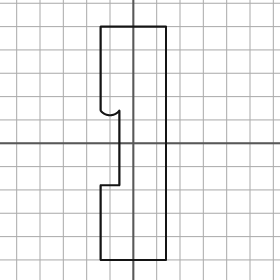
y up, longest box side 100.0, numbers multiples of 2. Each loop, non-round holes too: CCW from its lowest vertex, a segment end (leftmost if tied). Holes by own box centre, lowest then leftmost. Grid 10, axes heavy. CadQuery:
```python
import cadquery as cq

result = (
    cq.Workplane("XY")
    .moveTo(-14.0, -50.0)
    .lineTo(14.0, -50.0)
    .lineTo(14.0, 50.0)
    .lineTo(-14.0, 50.0)
    .lineTo(-14.0, 14.0)
    .threePointArc((-10.0, 12.0), (-6.0, 14.0))
    .lineTo(-6.0, -18.0)
    .lineTo(-14.0, -18.0)
    .close()
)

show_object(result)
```